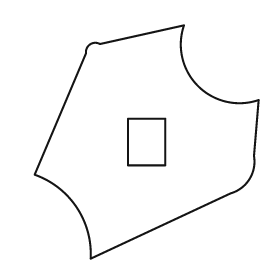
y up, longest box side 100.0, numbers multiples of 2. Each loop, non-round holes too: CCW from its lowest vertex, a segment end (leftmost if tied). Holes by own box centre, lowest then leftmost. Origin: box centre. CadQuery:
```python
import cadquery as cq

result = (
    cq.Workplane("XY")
    .moveTo(-24.0, -50.0)
    .lineTo(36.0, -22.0)
    .threePointArc((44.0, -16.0), (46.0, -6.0))
    .lineTo(48.0, 18.0)
    .threePointArc((22.0, 24.0), (16.0, 50.0))
    .lineTo(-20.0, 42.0)
    .threePointArc((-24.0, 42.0), (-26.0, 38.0))
    .lineTo(-48.0, -14.0)
    .threePointArc((-30.0, -28.0), (-24.0, -50.0))
    .close()
    .moveTo(-8.0, -10.0)
    .lineTo(8.0, -10.0)
    .lineTo(8.0, 10.0)
    .lineTo(-8.0, 10.0)
    .close()
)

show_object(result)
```